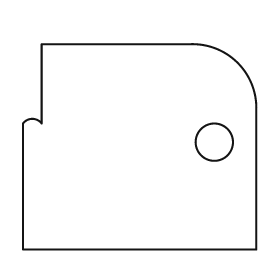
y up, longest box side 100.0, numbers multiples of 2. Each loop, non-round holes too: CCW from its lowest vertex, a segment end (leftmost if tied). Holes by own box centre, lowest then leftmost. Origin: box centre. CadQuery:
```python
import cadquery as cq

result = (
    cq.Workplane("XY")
    .moveTo(-50.0, -44.0)
    .lineTo(50.0, -44.0)
    .lineTo(50.0, 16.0)
    .threePointArc((42.0, 36.0), (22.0, 44.0))
    .lineTo(-42.0, 44.0)
    .lineTo(-42.0, 10.0)
    .threePointArc((-46.0, 12.0), (-50.0, 10.0))
    .close()
    .moveTo(32.0, 2.0)
    .circle(8.0)
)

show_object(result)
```